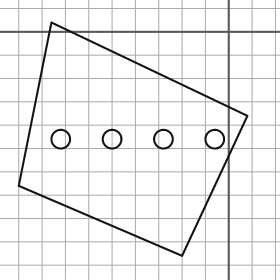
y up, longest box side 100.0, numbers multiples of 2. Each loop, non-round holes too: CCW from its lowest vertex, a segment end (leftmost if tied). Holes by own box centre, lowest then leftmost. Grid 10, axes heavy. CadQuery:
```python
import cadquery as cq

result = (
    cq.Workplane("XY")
    .moveTo(-20.0, -96.0)
    .lineTo(8.0, -36.0)
    .lineTo(-76.0, 4.0)
    .lineTo(-90.0, -66.0)
    .close()
    .moveTo(-72.0, -46.0)
    .circle(4.0)
    .moveTo(-50.0, -46.0)
    .circle(4.0)
    .moveTo(-28.0, -46.0)
    .circle(4.0)
    .moveTo(-6.0, -46.0)
    .circle(4.0)
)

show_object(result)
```